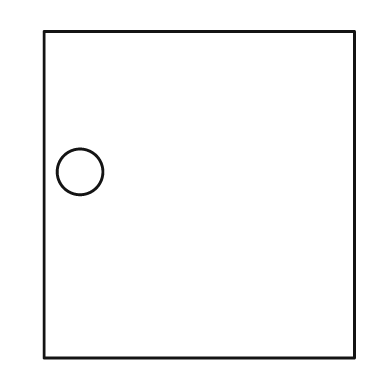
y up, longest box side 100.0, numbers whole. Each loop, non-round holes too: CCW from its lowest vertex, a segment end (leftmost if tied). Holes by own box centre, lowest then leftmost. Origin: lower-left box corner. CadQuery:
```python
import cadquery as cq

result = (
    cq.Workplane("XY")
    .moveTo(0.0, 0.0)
    .lineTo(95.0, 0.0)
    .lineTo(95.0, 100.0)
    .lineTo(0.0, 100.0)
    .close()
    .moveTo(11.0, 57.0)
    .circle(7.0)
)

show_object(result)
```